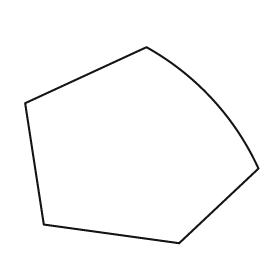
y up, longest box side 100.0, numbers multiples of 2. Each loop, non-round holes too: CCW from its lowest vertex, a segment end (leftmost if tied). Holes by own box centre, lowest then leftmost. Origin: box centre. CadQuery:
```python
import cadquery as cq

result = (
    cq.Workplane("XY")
    .moveTo(16.0, -42.0)
    .lineTo(50.0, -10.0)
    .threePointArc((30.0, 20.0), (2.0, 42.0))
    .lineTo(-50.0, 18.0)
    .lineTo(-42.0, -34.0)
    .close()
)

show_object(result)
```